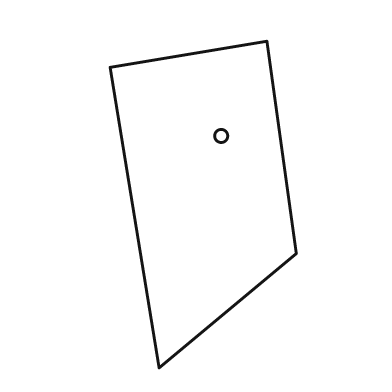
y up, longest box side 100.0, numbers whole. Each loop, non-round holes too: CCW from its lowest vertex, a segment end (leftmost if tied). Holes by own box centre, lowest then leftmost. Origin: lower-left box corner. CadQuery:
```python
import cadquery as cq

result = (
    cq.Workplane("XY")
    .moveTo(15.0, 0.0)
    .lineTo(57.0, 35.0)
    .lineTo(48.0, 100.0)
    .lineTo(0.0, 92.0)
    .close()
    .moveTo(34.0, 71.0)
    .circle(2.0)
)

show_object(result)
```